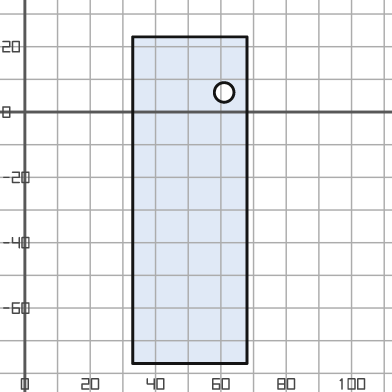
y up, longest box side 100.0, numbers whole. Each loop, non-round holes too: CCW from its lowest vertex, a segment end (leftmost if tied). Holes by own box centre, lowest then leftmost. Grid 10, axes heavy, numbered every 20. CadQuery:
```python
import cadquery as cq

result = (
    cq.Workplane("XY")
    .moveTo(33.0, -77.0)
    .lineTo(68.0, -77.0)
    .lineTo(68.0, 23.0)
    .lineTo(33.0, 23.0)
    .close()
    .moveTo(61.0, 6.0)
    .circle(3.0)
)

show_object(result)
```